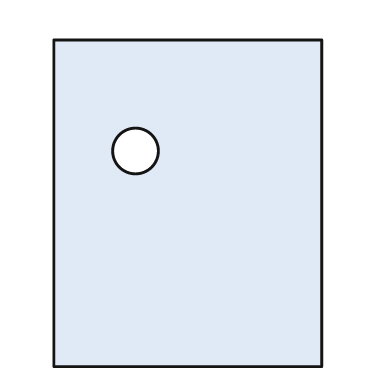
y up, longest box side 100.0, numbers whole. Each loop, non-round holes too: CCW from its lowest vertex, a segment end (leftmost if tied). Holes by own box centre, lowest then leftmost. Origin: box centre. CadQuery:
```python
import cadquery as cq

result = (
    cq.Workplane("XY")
    .moveTo(-41.0, -50.0)
    .lineTo(41.0, -50.0)
    .lineTo(41.0, 50.0)
    .lineTo(-41.0, 50.0)
    .close()
    .moveTo(-16.0, 16.0)
    .circle(7.0)
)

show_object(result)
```